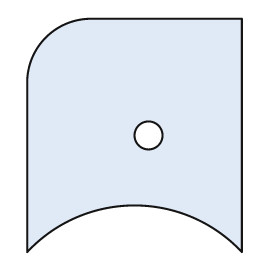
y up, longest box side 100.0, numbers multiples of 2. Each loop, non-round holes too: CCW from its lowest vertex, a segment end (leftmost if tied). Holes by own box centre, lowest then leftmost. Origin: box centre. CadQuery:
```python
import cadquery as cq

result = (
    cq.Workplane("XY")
    .moveTo(-46.0, -50.0)
    .threePointArc((0.0, -30.0), (46.0, -50.0))
    .lineTo(46.0, 50.0)
    .lineTo(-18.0, 50.0)
    .threePointArc((-38.0, 42.0), (-46.0, 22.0))
    .close()
    .moveTo(6.0, 0.0)
    .circle(6.0)
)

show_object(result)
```